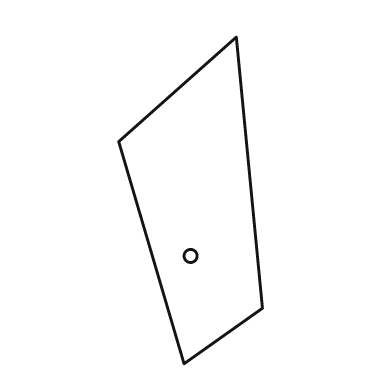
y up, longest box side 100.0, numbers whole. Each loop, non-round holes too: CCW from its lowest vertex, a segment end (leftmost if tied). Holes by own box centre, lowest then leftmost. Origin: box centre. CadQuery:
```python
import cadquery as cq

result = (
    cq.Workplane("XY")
    .moveTo(-2.0, -50.0)
    .lineTo(22.0, -33.0)
    .lineTo(14.0, 50.0)
    .lineTo(-22.0, 18.0)
    .close()
    .moveTo(0.0, -17.0)
    .circle(2.0)
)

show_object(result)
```